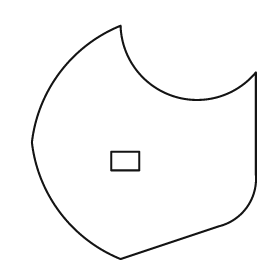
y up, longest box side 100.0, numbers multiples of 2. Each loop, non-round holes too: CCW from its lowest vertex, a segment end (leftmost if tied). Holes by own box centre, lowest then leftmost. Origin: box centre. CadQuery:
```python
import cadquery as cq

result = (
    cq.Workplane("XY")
    .moveTo(-10.0, -50.0)
    .lineTo(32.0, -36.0)
    .threePointArc((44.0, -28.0), (48.0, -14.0))
    .lineTo(48.0, 30.0)
    .threePointArc((12.0, 20.0), (-10.0, 50.0))
    .threePointArc((-36.0, 30.0), (-48.0, 0.0))
    .threePointArc((-36.0, -30.0), (-10.0, -50.0))
    .close()
    .moveTo(-14.0, -12.0)
    .lineTo(-2.0, -12.0)
    .lineTo(-2.0, -4.0)
    .lineTo(-14.0, -4.0)
    .close()
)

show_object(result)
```